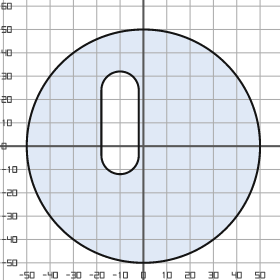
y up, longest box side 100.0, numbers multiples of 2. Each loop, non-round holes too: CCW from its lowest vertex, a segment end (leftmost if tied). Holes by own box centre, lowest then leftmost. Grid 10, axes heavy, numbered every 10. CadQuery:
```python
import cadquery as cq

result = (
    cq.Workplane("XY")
    .moveTo(0.0, 0.0)
    .circle(50.0)
    .moveTo(-18.0, -4.0)
    .threePointArc((-10.0, -12.0), (-2.0, -4.0))
    .lineTo(-2.0, 24.0)
    .threePointArc((-10.0, 32.0), (-18.0, 24.0))
    .close()
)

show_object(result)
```